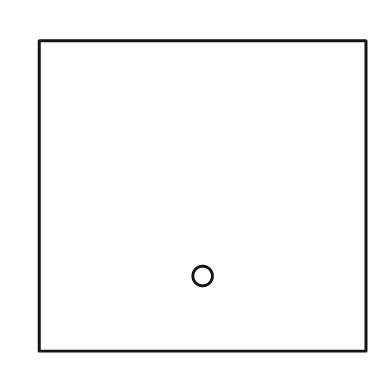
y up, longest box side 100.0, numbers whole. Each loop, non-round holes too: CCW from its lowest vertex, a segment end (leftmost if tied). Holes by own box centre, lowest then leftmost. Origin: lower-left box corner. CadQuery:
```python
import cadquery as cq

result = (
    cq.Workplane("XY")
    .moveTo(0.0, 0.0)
    .lineTo(100.0, 0.0)
    .lineTo(100.0, 95.0)
    .lineTo(0.0, 95.0)
    .close()
    .moveTo(50.0, 23.0)
    .circle(3.0)
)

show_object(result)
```